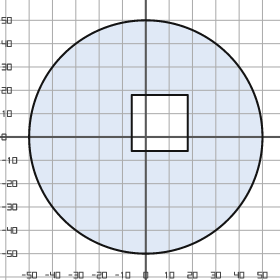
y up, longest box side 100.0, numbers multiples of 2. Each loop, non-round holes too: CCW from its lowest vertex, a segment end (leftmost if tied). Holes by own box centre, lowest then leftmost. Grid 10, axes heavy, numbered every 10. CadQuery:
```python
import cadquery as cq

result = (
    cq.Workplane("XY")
    .moveTo(0.0, 0.0)
    .circle(50.0)
    .moveTo(-6.0, -6.0)
    .lineTo(18.0, -6.0)
    .lineTo(18.0, 18.0)
    .lineTo(-6.0, 18.0)
    .close()
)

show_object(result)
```